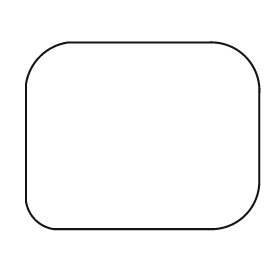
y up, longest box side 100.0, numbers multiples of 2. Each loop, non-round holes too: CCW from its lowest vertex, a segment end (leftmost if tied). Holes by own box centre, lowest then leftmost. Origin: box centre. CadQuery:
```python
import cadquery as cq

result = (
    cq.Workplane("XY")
    .moveTo(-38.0, -40.0)
    .lineTo(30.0, -40.0)
    .threePointArc((44.0, -34.0), (50.0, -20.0))
    .lineTo(50.0, 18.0)
    .threePointArc((44.0, 34.0), (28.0, 40.0))
    .lineTo(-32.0, 40.0)
    .threePointArc((-44.0, 34.0), (-50.0, 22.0))
    .lineTo(-50.0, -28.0)
    .threePointArc((-46.0, -36.0), (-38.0, -40.0))
    .close()
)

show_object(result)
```